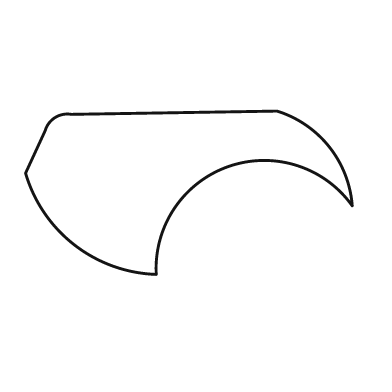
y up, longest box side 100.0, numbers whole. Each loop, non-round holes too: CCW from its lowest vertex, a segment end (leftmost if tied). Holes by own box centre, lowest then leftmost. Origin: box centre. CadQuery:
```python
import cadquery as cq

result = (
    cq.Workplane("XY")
    .moveTo(-10.0, -25.0)
    .threePointArc((12.0, 8.0), (50.0, -4.0))
    .threePointArc((43.0, 14.0), (27.0, 25.0))
    .lineTo(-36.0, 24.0)
    .threePointArc((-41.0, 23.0), (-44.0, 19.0))
    .lineTo(-50.0, 6.0)
    .threePointArc((-35.0, -16.0), (-10.0, -25.0))
    .close()
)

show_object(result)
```